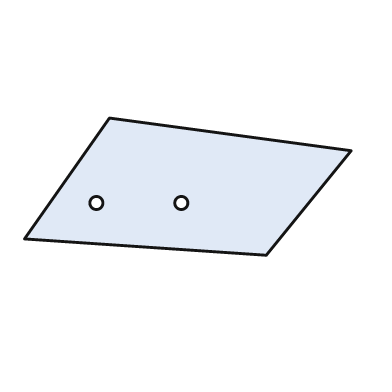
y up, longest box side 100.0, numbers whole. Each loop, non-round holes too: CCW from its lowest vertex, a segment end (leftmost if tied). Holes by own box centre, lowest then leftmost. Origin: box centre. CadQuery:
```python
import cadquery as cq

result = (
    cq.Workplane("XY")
    .moveTo(24.0, -21.0)
    .lineTo(50.0, 11.0)
    .lineTo(-24.0, 21.0)
    .lineTo(-50.0, -16.0)
    .close()
    .moveTo(-28.0, -5.0)
    .circle(2.0)
    .moveTo(-2.0, -5.0)
    .circle(2.0)
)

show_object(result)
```